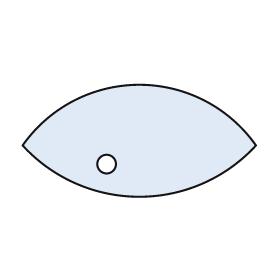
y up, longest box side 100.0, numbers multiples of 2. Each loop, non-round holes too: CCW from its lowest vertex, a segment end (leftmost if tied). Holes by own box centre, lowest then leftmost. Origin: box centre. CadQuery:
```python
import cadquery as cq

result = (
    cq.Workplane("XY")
    .moveTo(-50.0, -2.0)
    .threePointArc((0.0, -24.0), (50.0, -2.0))
    .threePointArc((0.0, 24.0), (-50.0, -2.0))
    .close()
    .moveTo(-14.0, -10.0)
    .circle(4.0)
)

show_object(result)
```